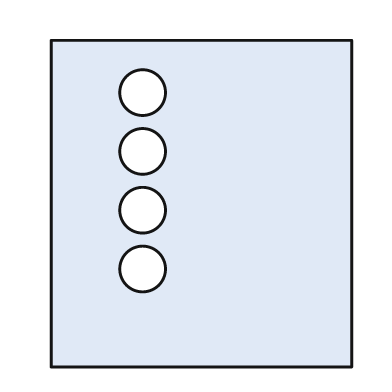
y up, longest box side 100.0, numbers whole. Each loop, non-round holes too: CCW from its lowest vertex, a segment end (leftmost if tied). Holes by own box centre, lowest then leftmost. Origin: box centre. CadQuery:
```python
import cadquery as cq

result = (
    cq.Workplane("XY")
    .moveTo(-46.0, -50.0)
    .lineTo(46.0, -50.0)
    .lineTo(46.0, 50.0)
    .lineTo(-46.0, 50.0)
    .close()
    .moveTo(-18.0, -20.0)
    .circle(7.0)
    .moveTo(-18.0, -2.0)
    .circle(7.0)
    .moveTo(-18.0, 16.0)
    .circle(7.0)
    .moveTo(-18.0, 34.0)
    .circle(7.0)
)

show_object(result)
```